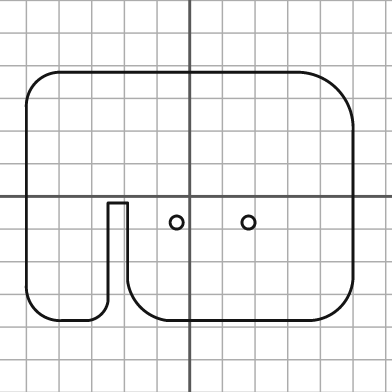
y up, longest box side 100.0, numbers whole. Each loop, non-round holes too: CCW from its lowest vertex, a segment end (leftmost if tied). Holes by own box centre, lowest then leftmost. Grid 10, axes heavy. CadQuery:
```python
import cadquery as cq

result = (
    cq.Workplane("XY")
    .moveTo(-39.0, -38.0)
    .lineTo(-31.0, -38.0)
    .threePointArc((-27.0, -36.0), (-25.0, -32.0))
    .lineTo(-25.0, -2.0)
    .lineTo(-19.0, -2.0)
    .lineTo(-19.0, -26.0)
    .threePointArc((-15.0, -34.0), (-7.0, -38.0))
    .lineTo(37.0, -38.0)
    .threePointArc((46.0, -34.0), (50.0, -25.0))
    .lineTo(50.0, 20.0)
    .threePointArc((45.0, 33.0), (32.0, 38.0))
    .lineTo(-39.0, 38.0)
    .threePointArc((-47.0, 35.0), (-50.0, 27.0))
    .lineTo(-50.0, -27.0)
    .threePointArc((-47.0, -35.0), (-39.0, -38.0))
    .close()
    .moveTo(-4.0, -8.0)
    .circle(2.0)
    .moveTo(18.0, -8.0)
    .circle(2.0)
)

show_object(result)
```